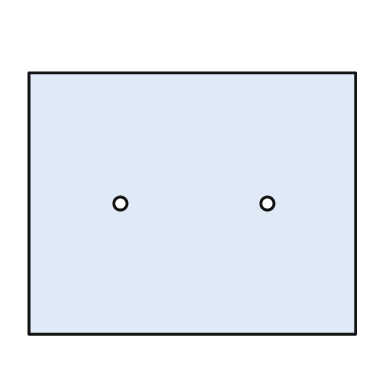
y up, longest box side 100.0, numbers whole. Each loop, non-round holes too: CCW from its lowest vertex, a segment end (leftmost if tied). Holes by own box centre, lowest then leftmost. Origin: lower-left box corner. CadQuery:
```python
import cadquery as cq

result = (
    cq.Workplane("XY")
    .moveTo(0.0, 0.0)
    .lineTo(100.0, 0.0)
    .lineTo(100.0, 80.0)
    .lineTo(0.0, 80.0)
    .close()
    .moveTo(28.0, 40.0)
    .circle(2.0)
    .moveTo(73.0, 40.0)
    .circle(2.0)
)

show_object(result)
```